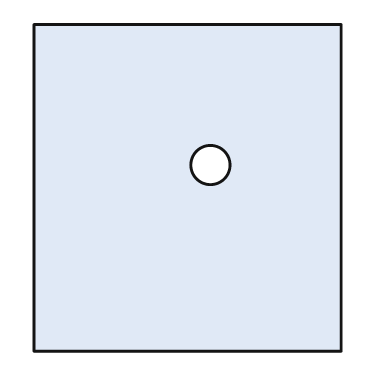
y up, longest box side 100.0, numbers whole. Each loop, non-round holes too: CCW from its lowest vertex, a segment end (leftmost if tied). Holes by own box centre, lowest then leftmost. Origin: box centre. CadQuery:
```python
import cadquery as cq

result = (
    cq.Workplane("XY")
    .moveTo(-47.0, -50.0)
    .lineTo(47.0, -50.0)
    .lineTo(47.0, 50.0)
    .lineTo(-47.0, 50.0)
    .close()
    .moveTo(7.0, 7.0)
    .circle(6.0)
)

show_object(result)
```